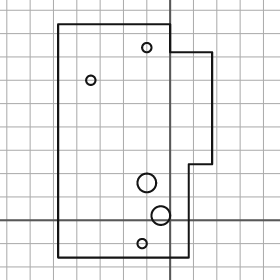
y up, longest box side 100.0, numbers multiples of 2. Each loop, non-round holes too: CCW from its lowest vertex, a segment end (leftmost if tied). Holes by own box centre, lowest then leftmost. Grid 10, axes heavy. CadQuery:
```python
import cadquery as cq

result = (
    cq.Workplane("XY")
    .moveTo(-48.0, -16.0)
    .lineTo(8.0, -16.0)
    .lineTo(8.0, 24.0)
    .lineTo(18.0, 24.0)
    .lineTo(18.0, 72.0)
    .lineTo(0.0, 72.0)
    .lineTo(0.0, 84.0)
    .lineTo(-48.0, 84.0)
    .close()
    .moveTo(-12.0, -10.0)
    .circle(2.0)
    .moveTo(-4.0, 2.0)
    .circle(4.0)
    .moveTo(-10.0, 16.0)
    .circle(4.0)
    .moveTo(-34.0, 60.0)
    .circle(2.0)
    .moveTo(-10.0, 74.0)
    .circle(2.0)
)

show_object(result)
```